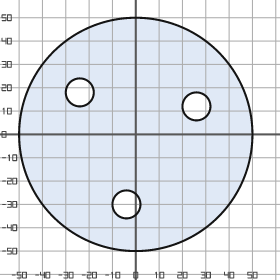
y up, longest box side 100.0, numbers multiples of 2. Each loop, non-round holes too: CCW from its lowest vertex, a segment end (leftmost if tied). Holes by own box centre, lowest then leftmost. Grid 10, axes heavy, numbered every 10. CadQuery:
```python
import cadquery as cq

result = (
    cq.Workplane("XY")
    .moveTo(0.0, 0.0)
    .circle(50.0)
    .moveTo(-4.0, -30.0)
    .circle(6.0)
    .moveTo(26.0, 12.0)
    .circle(6.0)
    .moveTo(-24.0, 18.0)
    .circle(6.0)
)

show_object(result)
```